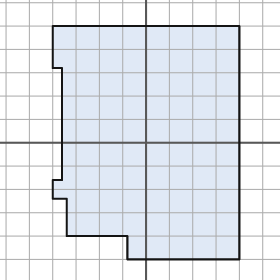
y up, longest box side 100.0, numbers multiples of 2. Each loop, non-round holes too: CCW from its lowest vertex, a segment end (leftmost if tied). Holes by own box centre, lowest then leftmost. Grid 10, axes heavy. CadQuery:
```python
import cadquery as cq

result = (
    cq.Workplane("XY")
    .moveTo(-8.0, -50.0)
    .lineTo(40.0, -50.0)
    .lineTo(40.0, 50.0)
    .lineTo(-40.0, 50.0)
    .lineTo(-40.0, 32.0)
    .lineTo(-36.0, 32.0)
    .lineTo(-36.0, -16.0)
    .lineTo(-40.0, -16.0)
    .lineTo(-40.0, -24.0)
    .lineTo(-34.0, -24.0)
    .lineTo(-34.0, -40.0)
    .lineTo(-8.0, -40.0)
    .close()
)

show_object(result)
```